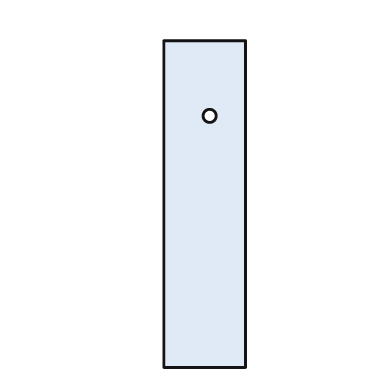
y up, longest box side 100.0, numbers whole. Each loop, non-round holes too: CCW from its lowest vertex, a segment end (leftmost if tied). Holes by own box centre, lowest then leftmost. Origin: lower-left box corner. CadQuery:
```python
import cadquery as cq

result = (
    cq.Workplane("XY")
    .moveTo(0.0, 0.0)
    .lineTo(25.0, 0.0)
    .lineTo(25.0, 100.0)
    .lineTo(0.0, 100.0)
    .close()
    .moveTo(14.0, 77.0)
    .circle(2.0)
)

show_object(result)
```